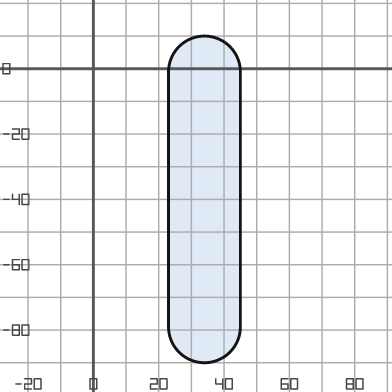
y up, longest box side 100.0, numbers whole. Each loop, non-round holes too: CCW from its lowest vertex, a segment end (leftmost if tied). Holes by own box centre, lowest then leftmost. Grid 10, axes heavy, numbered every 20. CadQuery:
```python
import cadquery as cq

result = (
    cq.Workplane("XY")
    .moveTo(23.0, -79.0)
    .threePointArc((34.0, -90.0), (45.0, -79.0))
    .lineTo(45.0, -1.0)
    .threePointArc((34.0, 10.0), (23.0, -1.0))
    .close()
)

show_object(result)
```